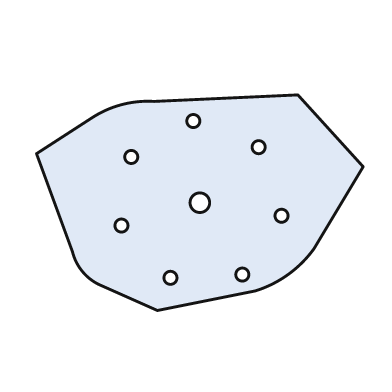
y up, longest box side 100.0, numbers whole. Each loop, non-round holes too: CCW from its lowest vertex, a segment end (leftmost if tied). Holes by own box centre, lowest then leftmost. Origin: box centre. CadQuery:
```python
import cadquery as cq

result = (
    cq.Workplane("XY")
    .moveTo(-13.0, -33.0)
    .lineTo(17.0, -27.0)
    .threePointArc((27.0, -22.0), (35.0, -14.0))
    .lineTo(50.0, 11.0)
    .lineTo(30.0, 33.0)
    .lineTo(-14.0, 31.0)
    .threePointArc((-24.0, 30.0), (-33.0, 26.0))
    .lineTo(-50.0, 15.0)
    .lineTo(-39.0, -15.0)
    .threePointArc((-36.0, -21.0), (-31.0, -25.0))
    .close()
    .moveTo(-9.0, -23.0)
    .circle(2.0)
    .moveTo(13.0, -22.0)
    .circle(2.0)
    .moveTo(-24.0, -7.0)
    .circle(2.0)
    .moveTo(25.0, -4.0)
    .circle(2.0)
    .moveTo(0.0, 0.0)
    .circle(3.0)
    .moveTo(-21.0, 14.0)
    .circle(2.0)
    .moveTo(18.0, 17.0)
    .circle(2.0)
    .moveTo(-2.0, 25.0)
    .circle(2.0)
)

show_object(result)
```